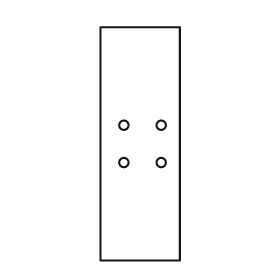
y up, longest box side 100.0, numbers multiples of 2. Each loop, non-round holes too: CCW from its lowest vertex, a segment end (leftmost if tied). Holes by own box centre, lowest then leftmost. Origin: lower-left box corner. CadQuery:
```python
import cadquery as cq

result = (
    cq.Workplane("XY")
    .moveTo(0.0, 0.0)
    .lineTo(34.0, 0.0)
    .lineTo(34.0, 100.0)
    .lineTo(0.0, 100.0)
    .close()
    .moveTo(10.0, 42.0)
    .circle(2.0)
    .moveTo(26.0, 42.0)
    .circle(2.0)
    .moveTo(10.0, 58.0)
    .circle(2.0)
    .moveTo(26.0, 58.0)
    .circle(2.0)
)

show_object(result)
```